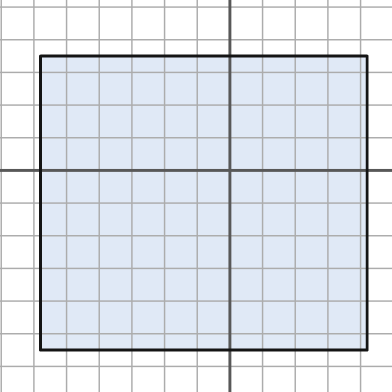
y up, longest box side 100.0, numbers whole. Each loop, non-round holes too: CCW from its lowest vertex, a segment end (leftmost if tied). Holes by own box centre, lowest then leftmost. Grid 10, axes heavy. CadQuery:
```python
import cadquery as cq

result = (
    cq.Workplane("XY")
    .moveTo(-58.0, -55.0)
    .lineTo(42.0, -55.0)
    .lineTo(42.0, 35.0)
    .lineTo(-58.0, 35.0)
    .close()
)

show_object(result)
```